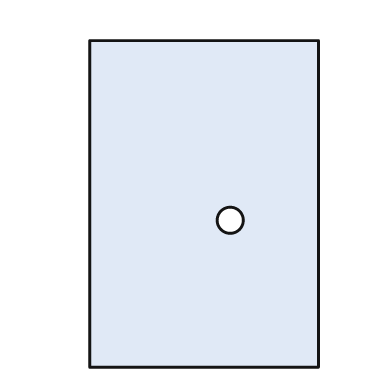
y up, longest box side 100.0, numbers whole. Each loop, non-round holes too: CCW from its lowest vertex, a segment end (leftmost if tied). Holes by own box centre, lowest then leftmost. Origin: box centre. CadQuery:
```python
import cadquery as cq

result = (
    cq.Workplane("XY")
    .moveTo(-35.0, -50.0)
    .lineTo(35.0, -50.0)
    .lineTo(35.0, 50.0)
    .lineTo(-35.0, 50.0)
    .close()
    .moveTo(8.0, -5.0)
    .circle(4.0)
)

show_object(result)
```